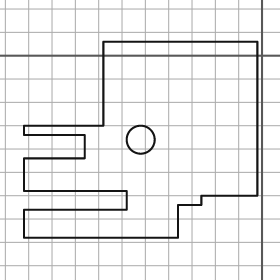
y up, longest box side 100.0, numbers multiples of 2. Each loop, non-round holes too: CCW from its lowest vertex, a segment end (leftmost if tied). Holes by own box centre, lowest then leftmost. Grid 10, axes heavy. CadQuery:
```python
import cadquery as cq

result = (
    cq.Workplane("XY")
    .moveTo(-102.0, -78.0)
    .lineTo(-36.0, -78.0)
    .lineTo(-36.0, -64.0)
    .lineTo(-26.0, -64.0)
    .lineTo(-26.0, -60.0)
    .lineTo(-2.0, -60.0)
    .lineTo(-2.0, 6.0)
    .lineTo(-68.0, 6.0)
    .lineTo(-68.0, -30.0)
    .lineTo(-102.0, -30.0)
    .lineTo(-102.0, -34.0)
    .lineTo(-76.0, -34.0)
    .lineTo(-76.0, -44.0)
    .lineTo(-102.0, -44.0)
    .lineTo(-102.0, -58.0)
    .lineTo(-58.0, -58.0)
    .lineTo(-58.0, -66.0)
    .lineTo(-102.0, -66.0)
    .close()
    .moveTo(-52.0, -36.0)
    .circle(6.0)
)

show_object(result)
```